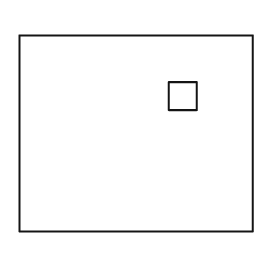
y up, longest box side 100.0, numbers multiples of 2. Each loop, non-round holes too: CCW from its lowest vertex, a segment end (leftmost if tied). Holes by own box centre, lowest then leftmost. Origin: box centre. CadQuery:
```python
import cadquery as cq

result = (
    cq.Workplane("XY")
    .moveTo(-50.0, -42.0)
    .lineTo(50.0, -42.0)
    .lineTo(50.0, 42.0)
    .lineTo(-50.0, 42.0)
    .close()
    .moveTo(14.0, 10.0)
    .lineTo(26.0, 10.0)
    .lineTo(26.0, 22.0)
    .lineTo(14.0, 22.0)
    .close()
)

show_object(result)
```